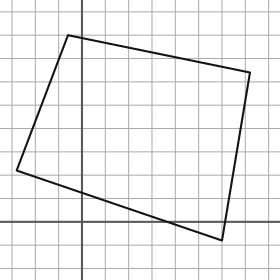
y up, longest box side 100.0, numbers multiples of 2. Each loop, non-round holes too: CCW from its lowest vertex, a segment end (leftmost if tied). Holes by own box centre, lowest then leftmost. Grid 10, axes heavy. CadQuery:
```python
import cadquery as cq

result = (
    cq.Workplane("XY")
    .moveTo(60.0, -8.0)
    .lineTo(72.0, 64.0)
    .lineTo(-6.0, 80.0)
    .lineTo(-28.0, 22.0)
    .close()
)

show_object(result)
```